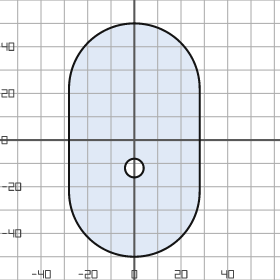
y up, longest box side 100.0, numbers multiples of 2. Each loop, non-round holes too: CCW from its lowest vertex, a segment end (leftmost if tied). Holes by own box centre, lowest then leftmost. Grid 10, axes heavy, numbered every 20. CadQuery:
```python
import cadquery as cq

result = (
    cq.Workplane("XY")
    .moveTo(-28.0, -22.0)
    .threePointArc((0.0, -50.0), (28.0, -22.0))
    .lineTo(28.0, 22.0)
    .threePointArc((0.0, 50.0), (-28.0, 22.0))
    .close()
    .moveTo(0.0, -12.0)
    .circle(4.0)
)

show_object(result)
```